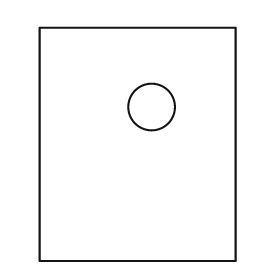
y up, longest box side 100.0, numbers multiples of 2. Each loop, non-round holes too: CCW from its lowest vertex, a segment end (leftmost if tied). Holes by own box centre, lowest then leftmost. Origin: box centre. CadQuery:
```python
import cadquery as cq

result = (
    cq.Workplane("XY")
    .moveTo(-42.0, -50.0)
    .lineTo(42.0, -50.0)
    .lineTo(42.0, 50.0)
    .lineTo(-42.0, 50.0)
    .close()
    .moveTo(6.0, 16.0)
    .circle(10.0)
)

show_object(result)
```